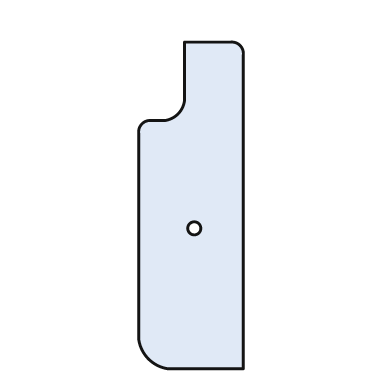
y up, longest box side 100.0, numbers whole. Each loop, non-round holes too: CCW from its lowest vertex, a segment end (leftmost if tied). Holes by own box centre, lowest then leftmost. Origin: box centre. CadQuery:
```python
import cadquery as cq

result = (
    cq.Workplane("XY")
    .moveTo(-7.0, -50.0)
    .lineTo(16.0, -50.0)
    .lineTo(16.0, 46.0)
    .threePointArc((15.0, 49.0), (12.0, 50.0))
    .lineTo(-2.0, 50.0)
    .lineTo(-2.0, 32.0)
    .threePointArc((-4.0, 28.0), (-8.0, 26.0))
    .lineTo(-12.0, 26.0)
    .threePointArc((-15.0, 25.0), (-16.0, 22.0))
    .lineTo(-16.0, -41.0)
    .threePointArc((-13.0, -47.0), (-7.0, -50.0))
    .close()
    .moveTo(1.0, -7.0)
    .circle(2.0)
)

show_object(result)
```